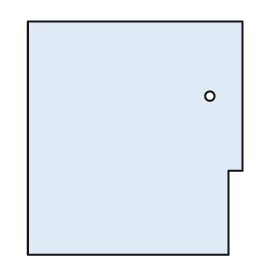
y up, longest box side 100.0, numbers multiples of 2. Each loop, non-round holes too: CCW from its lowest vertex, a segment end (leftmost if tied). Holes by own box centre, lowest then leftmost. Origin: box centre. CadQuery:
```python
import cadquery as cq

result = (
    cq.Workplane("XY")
    .moveTo(-46.0, -50.0)
    .lineTo(40.0, -50.0)
    .lineTo(40.0, -14.0)
    .lineTo(46.0, -14.0)
    .lineTo(46.0, 50.0)
    .lineTo(-46.0, 50.0)
    .close()
    .moveTo(32.0, 18.0)
    .circle(2.0)
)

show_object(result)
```